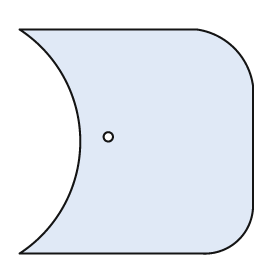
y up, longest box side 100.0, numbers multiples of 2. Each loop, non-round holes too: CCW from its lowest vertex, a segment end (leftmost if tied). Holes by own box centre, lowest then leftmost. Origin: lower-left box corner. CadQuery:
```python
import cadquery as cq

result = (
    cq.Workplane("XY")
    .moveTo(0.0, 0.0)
    .lineTo(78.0, 0.0)
    .threePointArc((94.0, 6.0), (100.0, 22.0))
    .lineTo(100.0, 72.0)
    .threePointArc((92.0, 88.0), (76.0, 96.0))
    .lineTo(0.0, 96.0)
    .threePointArc((26.0, 48.0), (0.0, 0.0))
    .close()
    .moveTo(38.0, 50.0)
    .circle(2.0)
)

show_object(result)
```